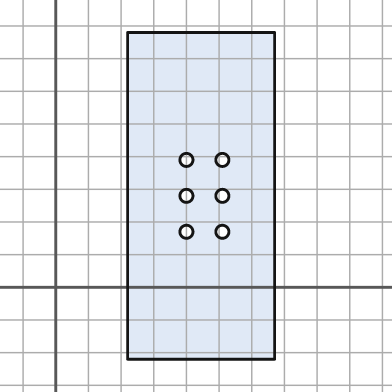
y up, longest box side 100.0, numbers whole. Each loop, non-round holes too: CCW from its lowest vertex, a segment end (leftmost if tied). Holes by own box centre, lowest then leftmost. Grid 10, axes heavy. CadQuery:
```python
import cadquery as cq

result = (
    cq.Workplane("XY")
    .moveTo(22.0, -22.0)
    .lineTo(67.0, -22.0)
    .lineTo(67.0, 78.0)
    .lineTo(22.0, 78.0)
    .close()
    .moveTo(40.0, 17.0)
    .circle(2.0)
    .moveTo(51.0, 17.0)
    .circle(2.0)
    .moveTo(40.0, 28.0)
    .circle(2.0)
    .moveTo(51.0, 28.0)
    .circle(2.0)
    .moveTo(40.0, 39.0)
    .circle(2.0)
    .moveTo(51.0, 39.0)
    .circle(2.0)
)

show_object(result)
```